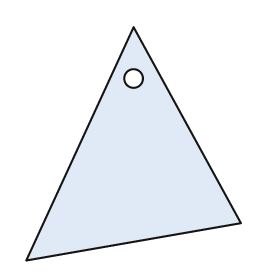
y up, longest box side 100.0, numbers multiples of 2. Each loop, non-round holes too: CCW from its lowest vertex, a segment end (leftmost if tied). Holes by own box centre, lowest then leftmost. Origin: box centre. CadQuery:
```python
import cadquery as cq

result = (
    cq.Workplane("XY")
    .moveTo(-46.0, -50.0)
    .lineTo(46.0, -34.0)
    .lineTo(0.0, 50.0)
    .close()
    .moveTo(0.0, 28.0)
    .circle(4.0)
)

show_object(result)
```